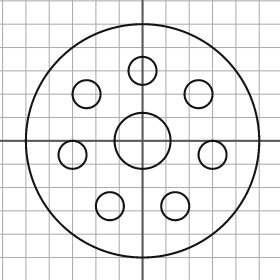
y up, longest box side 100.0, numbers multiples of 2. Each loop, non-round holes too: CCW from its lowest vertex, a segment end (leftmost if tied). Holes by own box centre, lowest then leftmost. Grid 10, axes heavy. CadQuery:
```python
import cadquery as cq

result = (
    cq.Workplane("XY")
    .moveTo(0.0, 0.0)
    .circle(50.0)
    .moveTo(-14.0, -28.0)
    .circle(6.0)
    .moveTo(14.0, -28.0)
    .circle(6.0)
    .moveTo(-30.0, -6.0)
    .circle(6.0)
    .moveTo(30.0, -6.0)
    .circle(6.0)
    .moveTo(0.0, 0.0)
    .circle(12.0)
    .moveTo(-24.0, 20.0)
    .circle(6.0)
    .moveTo(24.0, 20.0)
    .circle(6.0)
    .moveTo(0.0, 30.0)
    .circle(6.0)
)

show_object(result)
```